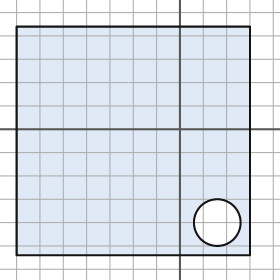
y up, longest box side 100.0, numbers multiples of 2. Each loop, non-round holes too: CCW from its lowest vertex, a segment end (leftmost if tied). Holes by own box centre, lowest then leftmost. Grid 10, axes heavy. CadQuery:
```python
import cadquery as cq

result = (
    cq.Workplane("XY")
    .moveTo(-70.0, -54.0)
    .lineTo(30.0, -54.0)
    .lineTo(30.0, 44.0)
    .lineTo(-70.0, 44.0)
    .close()
    .moveTo(16.0, -40.0)
    .circle(10.0)
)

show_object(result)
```